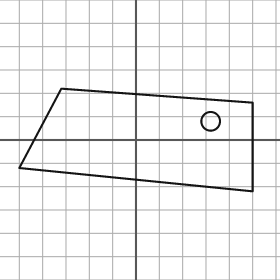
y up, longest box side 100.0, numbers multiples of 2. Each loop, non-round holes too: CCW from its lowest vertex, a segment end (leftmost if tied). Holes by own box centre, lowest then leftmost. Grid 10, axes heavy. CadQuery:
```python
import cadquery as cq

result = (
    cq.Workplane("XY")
    .moveTo(50.0, -22.0)
    .lineTo(50.0, 16.0)
    .lineTo(-32.0, 22.0)
    .lineTo(-50.0, -12.0)
    .close()
    .moveTo(32.0, 8.0)
    .circle(4.0)
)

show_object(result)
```